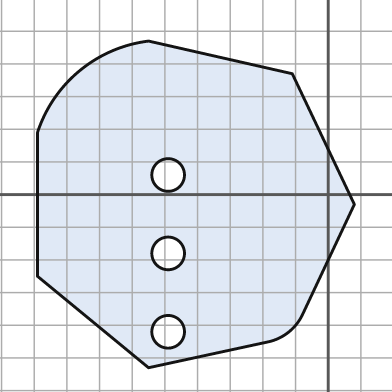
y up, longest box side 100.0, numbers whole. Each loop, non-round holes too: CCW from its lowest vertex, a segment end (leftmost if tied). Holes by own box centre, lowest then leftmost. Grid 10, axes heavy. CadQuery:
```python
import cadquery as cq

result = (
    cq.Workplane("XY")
    .moveTo(-55.0, -53.0)
    .lineTo(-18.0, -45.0)
    .threePointArc((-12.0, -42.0), (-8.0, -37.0))
    .lineTo(8.0, -3.0)
    .lineTo(-11.0, 37.0)
    .lineTo(-55.0, 47.0)
    .threePointArc((-76.0, 38.0), (-89.0, 19.0))
    .lineTo(-89.0, -25.0)
    .close()
    .moveTo(-49.0, -42.0)
    .circle(5.0)
    .moveTo(-49.0, -18.0)
    .circle(5.0)
    .moveTo(-49.0, 6.0)
    .circle(5.0)
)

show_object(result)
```